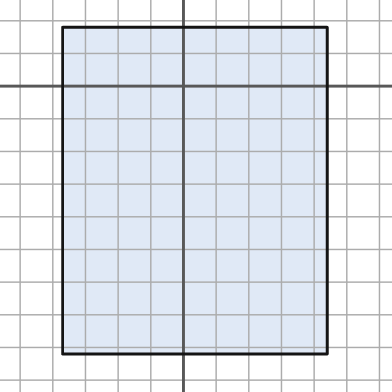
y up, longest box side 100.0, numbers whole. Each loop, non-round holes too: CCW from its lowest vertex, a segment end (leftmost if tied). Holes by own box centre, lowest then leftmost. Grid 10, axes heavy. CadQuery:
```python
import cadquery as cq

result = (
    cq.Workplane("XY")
    .moveTo(-37.0, -82.0)
    .lineTo(44.0, -82.0)
    .lineTo(44.0, 18.0)
    .lineTo(-37.0, 18.0)
    .close()
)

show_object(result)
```